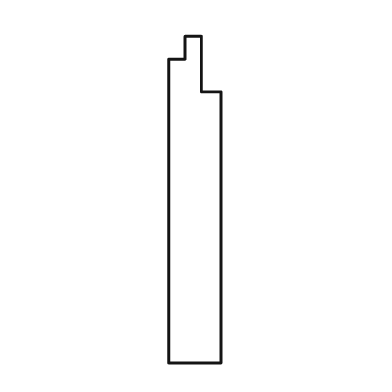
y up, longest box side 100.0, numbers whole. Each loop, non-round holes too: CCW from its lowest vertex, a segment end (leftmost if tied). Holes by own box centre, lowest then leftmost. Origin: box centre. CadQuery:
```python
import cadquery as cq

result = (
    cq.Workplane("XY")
    .moveTo(-8.0, -50.0)
    .lineTo(8.0, -50.0)
    .lineTo(8.0, 33.0)
    .lineTo(2.0, 33.0)
    .lineTo(2.0, 50.0)
    .lineTo(-3.0, 50.0)
    .lineTo(-3.0, 43.0)
    .lineTo(-8.0, 43.0)
    .close()
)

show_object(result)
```